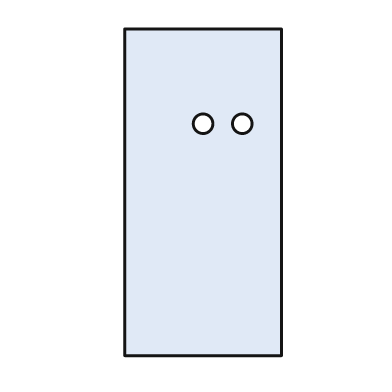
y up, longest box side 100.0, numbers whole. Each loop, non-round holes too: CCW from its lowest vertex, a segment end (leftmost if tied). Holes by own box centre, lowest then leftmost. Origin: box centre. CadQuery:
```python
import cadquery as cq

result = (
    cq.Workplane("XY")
    .moveTo(-24.0, -50.0)
    .lineTo(24.0, -50.0)
    .lineTo(24.0, 50.0)
    .lineTo(-24.0, 50.0)
    .close()
    .moveTo(0.0, 21.0)
    .circle(3.0)
    .moveTo(12.0, 21.0)
    .circle(3.0)
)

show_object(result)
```